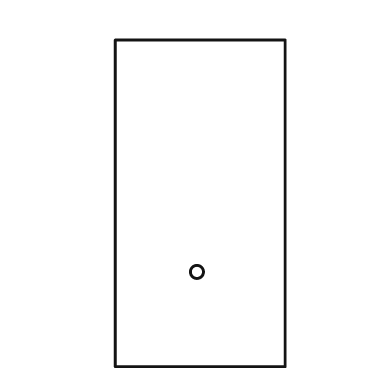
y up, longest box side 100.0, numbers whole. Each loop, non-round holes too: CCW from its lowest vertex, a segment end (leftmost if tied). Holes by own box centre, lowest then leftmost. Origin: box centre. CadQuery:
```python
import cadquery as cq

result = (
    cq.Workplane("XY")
    .moveTo(-26.0, -50.0)
    .lineTo(26.0, -50.0)
    .lineTo(26.0, 50.0)
    .lineTo(-26.0, 50.0)
    .close()
    .moveTo(-1.0, -21.0)
    .circle(2.0)
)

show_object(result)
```